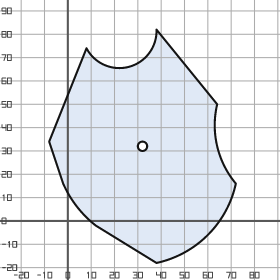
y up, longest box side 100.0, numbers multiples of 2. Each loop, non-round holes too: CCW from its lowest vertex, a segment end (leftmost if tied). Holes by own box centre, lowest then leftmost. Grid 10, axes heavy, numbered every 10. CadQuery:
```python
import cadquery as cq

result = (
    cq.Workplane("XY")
    .moveTo(38.0, -18.0)
    .threePointArc((60.0, -6.0), (72.0, 16.0))
    .threePointArc((64.0, 32.0), (64.0, 50.0))
    .lineTo(38.0, 82.0)
    .threePointArc((26.0, 66.0), (8.0, 74.0))
    .lineTo(-8.0, 34.0)
    .lineTo(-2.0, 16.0)
    .threePointArc((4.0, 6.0), (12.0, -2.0))
    .close()
    .moveTo(32.0, 32.0)
    .circle(2.0)
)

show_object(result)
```